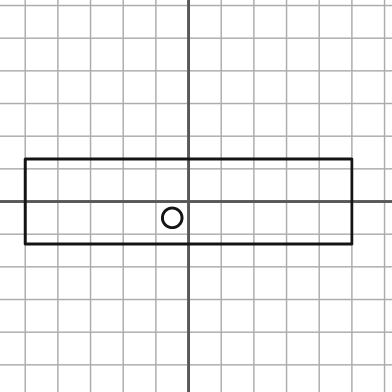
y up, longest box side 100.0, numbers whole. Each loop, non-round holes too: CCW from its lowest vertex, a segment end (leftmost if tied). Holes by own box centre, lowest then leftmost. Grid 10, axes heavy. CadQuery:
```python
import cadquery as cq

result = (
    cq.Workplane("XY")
    .moveTo(-50.0, -13.0)
    .lineTo(50.0, -13.0)
    .lineTo(50.0, 13.0)
    .lineTo(-50.0, 13.0)
    .close()
    .moveTo(-5.0, -5.0)
    .circle(3.0)
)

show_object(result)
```